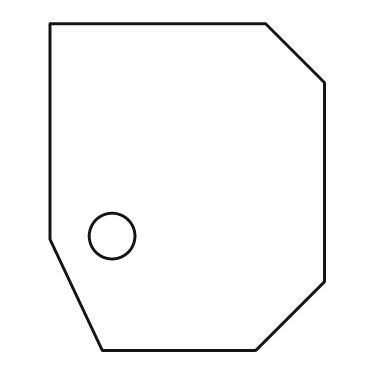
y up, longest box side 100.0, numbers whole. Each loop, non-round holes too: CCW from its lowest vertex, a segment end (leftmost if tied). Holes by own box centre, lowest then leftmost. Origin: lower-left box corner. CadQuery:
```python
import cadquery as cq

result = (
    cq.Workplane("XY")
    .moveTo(16.0, 0.0)
    .lineTo(63.0, 0.0)
    .lineTo(84.0, 21.0)
    .lineTo(84.0, 82.0)
    .lineTo(66.0, 100.0)
    .lineTo(0.0, 100.0)
    .lineTo(0.0, 34.0)
    .close()
    .moveTo(19.0, 35.0)
    .circle(7.0)
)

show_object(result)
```